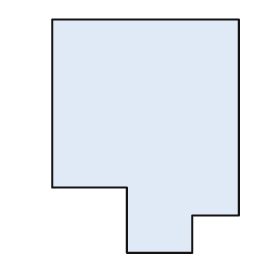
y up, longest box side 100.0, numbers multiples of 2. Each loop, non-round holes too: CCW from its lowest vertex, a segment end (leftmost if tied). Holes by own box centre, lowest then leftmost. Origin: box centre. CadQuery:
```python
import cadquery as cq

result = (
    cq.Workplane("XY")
    .moveTo(-8.0, -50.0)
    .lineTo(20.0, -50.0)
    .lineTo(20.0, -34.0)
    .lineTo(40.0, -34.0)
    .lineTo(40.0, 50.0)
    .lineTo(-40.0, 50.0)
    .lineTo(-40.0, -22.0)
    .lineTo(-8.0, -22.0)
    .close()
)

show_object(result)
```